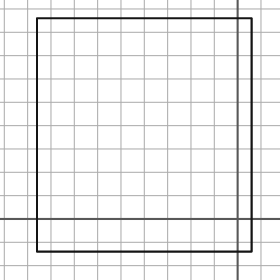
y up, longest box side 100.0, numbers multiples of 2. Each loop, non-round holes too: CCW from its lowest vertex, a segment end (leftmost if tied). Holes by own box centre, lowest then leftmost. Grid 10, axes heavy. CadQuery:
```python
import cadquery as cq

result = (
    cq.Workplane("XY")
    .moveTo(-86.0, -14.0)
    .lineTo(6.0, -14.0)
    .lineTo(6.0, 86.0)
    .lineTo(-86.0, 86.0)
    .close()
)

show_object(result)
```